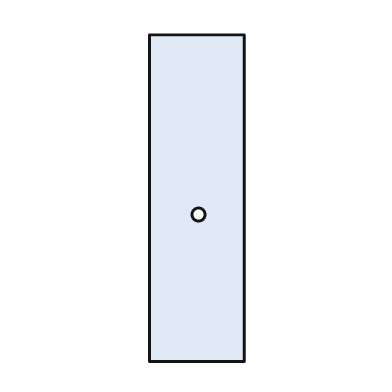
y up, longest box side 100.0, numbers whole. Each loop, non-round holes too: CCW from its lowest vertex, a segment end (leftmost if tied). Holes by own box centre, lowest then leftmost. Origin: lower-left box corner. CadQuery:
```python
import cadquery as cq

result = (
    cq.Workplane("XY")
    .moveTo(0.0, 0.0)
    .lineTo(29.0, 0.0)
    .lineTo(29.0, 100.0)
    .lineTo(0.0, 100.0)
    .close()
    .moveTo(15.0, 45.0)
    .circle(2.0)
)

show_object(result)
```